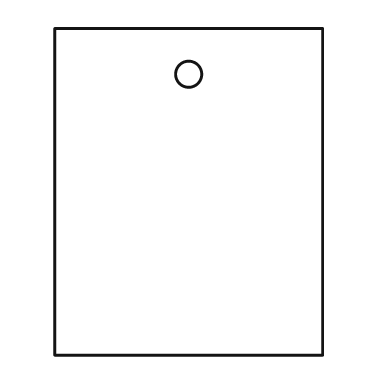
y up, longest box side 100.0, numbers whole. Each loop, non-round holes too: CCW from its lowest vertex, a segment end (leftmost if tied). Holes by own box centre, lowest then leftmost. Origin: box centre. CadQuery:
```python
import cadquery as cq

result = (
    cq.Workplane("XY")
    .moveTo(-41.0, -50.0)
    .lineTo(41.0, -50.0)
    .lineTo(41.0, 50.0)
    .lineTo(-41.0, 50.0)
    .close()
    .moveTo(0.0, 36.0)
    .circle(4.0)
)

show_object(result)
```